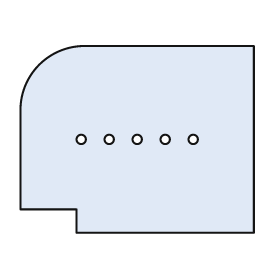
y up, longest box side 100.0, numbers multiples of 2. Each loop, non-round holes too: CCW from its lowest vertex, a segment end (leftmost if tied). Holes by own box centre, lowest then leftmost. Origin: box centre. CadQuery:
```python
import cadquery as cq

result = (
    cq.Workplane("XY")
    .moveTo(-26.0, -40.0)
    .lineTo(50.0, -40.0)
    .lineTo(50.0, 40.0)
    .lineTo(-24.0, 40.0)
    .threePointArc((-42.0, 32.0), (-50.0, 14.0))
    .lineTo(-50.0, -30.0)
    .lineTo(-26.0, -30.0)
    .close()
    .moveTo(-24.0, 0.0)
    .circle(2.0)
    .moveTo(-12.0, 0.0)
    .circle(2.0)
    .moveTo(0.0, 0.0)
    .circle(2.0)
    .moveTo(12.0, 0.0)
    .circle(2.0)
    .moveTo(24.0, 0.0)
    .circle(2.0)
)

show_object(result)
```